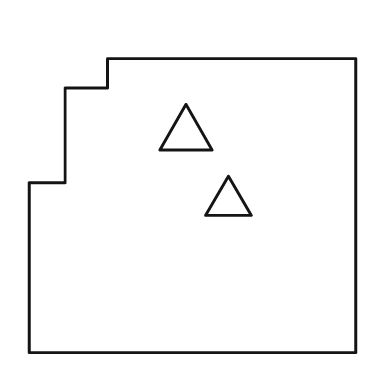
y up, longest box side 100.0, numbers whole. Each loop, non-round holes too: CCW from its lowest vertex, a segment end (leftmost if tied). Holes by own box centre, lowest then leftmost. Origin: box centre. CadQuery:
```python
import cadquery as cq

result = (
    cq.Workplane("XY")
    .moveTo(-50.0, -45.0)
    .lineTo(50.0, -45.0)
    .lineTo(50.0, 45.0)
    .lineTo(-26.0, 45.0)
    .lineTo(-26.0, 36.0)
    .lineTo(-39.0, 36.0)
    .lineTo(-39.0, 7.0)
    .lineTo(-50.0, 7.0)
    .close()
    .moveTo(4.0, -3.0)
    .lineTo(18.0, -3.0)
    .lineTo(11.0, 9.0)
    .close()
    .moveTo(-10.0, 17.0)
    .lineTo(6.0, 17.0)
    .lineTo(-2.0, 31.0)
    .close()
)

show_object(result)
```